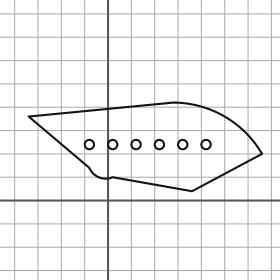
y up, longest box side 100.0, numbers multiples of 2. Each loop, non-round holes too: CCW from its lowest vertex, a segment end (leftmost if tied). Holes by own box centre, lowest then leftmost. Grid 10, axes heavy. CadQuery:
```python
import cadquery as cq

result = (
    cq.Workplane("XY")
    .moveTo(36.0, 4.0)
    .lineTo(66.0, 20.0)
    .threePointArc((50.0, 36.0), (28.0, 42.0))
    .lineTo(-34.0, 36.0)
    .lineTo(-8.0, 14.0)
    .threePointArc((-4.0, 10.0), (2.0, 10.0))
    .close()
    .moveTo(-8.0, 24.0)
    .circle(2.0)
    .moveTo(2.0, 24.0)
    .circle(2.0)
    .moveTo(12.0, 24.0)
    .circle(2.0)
    .moveTo(22.0, 24.0)
    .circle(2.0)
    .moveTo(32.0, 24.0)
    .circle(2.0)
    .moveTo(42.0, 24.0)
    .circle(2.0)
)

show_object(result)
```